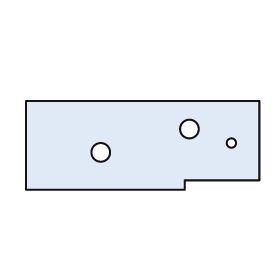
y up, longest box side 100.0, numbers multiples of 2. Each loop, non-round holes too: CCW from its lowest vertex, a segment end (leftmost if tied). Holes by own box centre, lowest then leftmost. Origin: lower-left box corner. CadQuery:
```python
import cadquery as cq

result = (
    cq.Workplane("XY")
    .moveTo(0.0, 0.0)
    .lineTo(68.0, 0.0)
    .lineTo(68.0, 4.0)
    .lineTo(100.0, 4.0)
    .lineTo(100.0, 38.0)
    .lineTo(0.0, 38.0)
    .close()
    .moveTo(32.0, 16.0)
    .circle(4.0)
    .moveTo(88.0, 20.0)
    .circle(2.0)
    .moveTo(70.0, 26.0)
    .circle(4.0)
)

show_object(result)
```